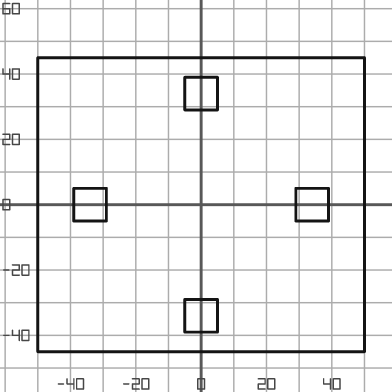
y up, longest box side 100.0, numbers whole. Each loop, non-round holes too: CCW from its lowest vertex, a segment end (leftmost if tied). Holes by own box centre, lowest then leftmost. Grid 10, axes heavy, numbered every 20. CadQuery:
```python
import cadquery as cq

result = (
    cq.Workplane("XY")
    .moveTo(-50.0, -45.0)
    .lineTo(50.0, -45.0)
    .lineTo(50.0, 45.0)
    .lineTo(-50.0, 45.0)
    .close()
    .moveTo(-5.0, -39.0)
    .lineTo(5.0, -39.0)
    .lineTo(5.0, -29.0)
    .lineTo(-5.0, -29.0)
    .close()
    .moveTo(-39.0, -5.0)
    .lineTo(-29.0, -5.0)
    .lineTo(-29.0, 5.0)
    .lineTo(-39.0, 5.0)
    .close()
    .moveTo(29.0, -5.0)
    .lineTo(39.0, -5.0)
    .lineTo(39.0, 5.0)
    .lineTo(29.0, 5.0)
    .close()
    .moveTo(-5.0, 29.0)
    .lineTo(5.0, 29.0)
    .lineTo(5.0, 39.0)
    .lineTo(-5.0, 39.0)
    .close()
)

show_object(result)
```